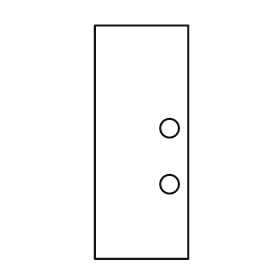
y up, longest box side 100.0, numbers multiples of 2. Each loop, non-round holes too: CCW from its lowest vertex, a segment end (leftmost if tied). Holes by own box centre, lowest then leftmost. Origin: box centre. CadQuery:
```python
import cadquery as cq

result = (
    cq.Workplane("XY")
    .moveTo(-20.0, -50.0)
    .lineTo(20.0, -50.0)
    .lineTo(20.0, 50.0)
    .lineTo(-20.0, 50.0)
    .close()
    .moveTo(12.0, -18.0)
    .circle(4.0)
    .moveTo(12.0, 6.0)
    .circle(4.0)
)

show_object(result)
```